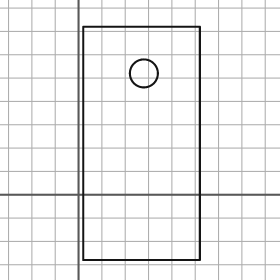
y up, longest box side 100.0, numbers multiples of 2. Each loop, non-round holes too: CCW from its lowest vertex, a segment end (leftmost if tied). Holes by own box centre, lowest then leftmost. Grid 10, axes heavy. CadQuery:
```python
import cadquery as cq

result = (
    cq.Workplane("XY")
    .moveTo(2.0, -28.0)
    .lineTo(52.0, -28.0)
    .lineTo(52.0, 72.0)
    .lineTo(2.0, 72.0)
    .close()
    .moveTo(28.0, 52.0)
    .circle(6.0)
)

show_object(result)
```